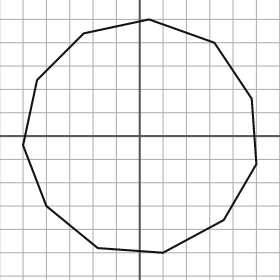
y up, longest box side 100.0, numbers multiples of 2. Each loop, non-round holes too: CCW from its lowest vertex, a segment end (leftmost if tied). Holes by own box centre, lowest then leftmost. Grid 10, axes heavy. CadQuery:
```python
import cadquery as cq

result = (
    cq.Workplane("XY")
    .moveTo(10.0, -50.0)
    .lineTo(36.0, -36.0)
    .lineTo(50.0, -12.0)
    .lineTo(48.0, 16.0)
    .lineTo(32.0, 40.0)
    .lineTo(4.0, 50.0)
    .lineTo(-24.0, 44.0)
    .lineTo(-44.0, 24.0)
    .lineTo(-50.0, -4.0)
    .lineTo(-40.0, -30.0)
    .lineTo(-18.0, -48.0)
    .close()
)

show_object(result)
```